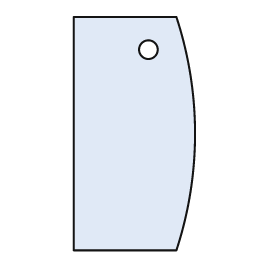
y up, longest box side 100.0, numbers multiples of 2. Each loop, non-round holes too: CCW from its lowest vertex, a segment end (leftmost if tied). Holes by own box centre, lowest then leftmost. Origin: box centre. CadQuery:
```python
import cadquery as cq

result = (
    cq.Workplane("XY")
    .moveTo(-26.0, -50.0)
    .lineTo(18.0, -50.0)
    .threePointArc((26.0, 0.0), (18.0, 50.0))
    .lineTo(-26.0, 50.0)
    .close()
    .moveTo(6.0, 36.0)
    .circle(4.0)
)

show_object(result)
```